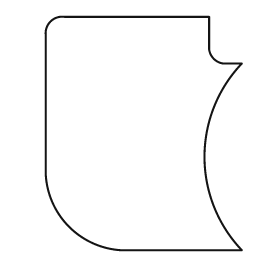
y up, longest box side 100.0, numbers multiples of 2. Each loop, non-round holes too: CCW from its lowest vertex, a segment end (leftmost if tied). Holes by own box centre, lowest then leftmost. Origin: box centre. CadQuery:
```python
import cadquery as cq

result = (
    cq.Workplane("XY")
    .moveTo(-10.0, -50.0)
    .lineTo(42.0, -50.0)
    .threePointArc((26.0, -10.0), (42.0, 30.0))
    .lineTo(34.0, 30.0)
    .threePointArc((30.0, 32.0), (28.0, 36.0))
    .lineTo(28.0, 50.0)
    .lineTo(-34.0, 50.0)
    .threePointArc((-40.0, 48.0), (-42.0, 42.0))
    .lineTo(-42.0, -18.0)
    .threePointArc((-32.0, -40.0), (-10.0, -50.0))
    .close()
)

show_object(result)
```